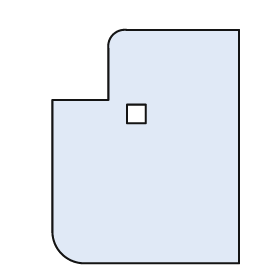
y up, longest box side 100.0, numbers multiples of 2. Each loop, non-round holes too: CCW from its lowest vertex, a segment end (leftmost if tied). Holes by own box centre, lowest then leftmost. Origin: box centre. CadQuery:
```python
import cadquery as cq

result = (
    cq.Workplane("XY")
    .moveTo(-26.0, -50.0)
    .lineTo(40.0, -50.0)
    .lineTo(40.0, 50.0)
    .lineTo(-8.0, 50.0)
    .threePointArc((-14.0, 48.0), (-16.0, 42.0))
    .lineTo(-16.0, 20.0)
    .lineTo(-40.0, 20.0)
    .lineTo(-40.0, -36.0)
    .threePointArc((-36.0, -46.0), (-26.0, -50.0))
    .close()
    .moveTo(-8.0, 10.0)
    .lineTo(0.0, 10.0)
    .lineTo(0.0, 18.0)
    .lineTo(-8.0, 18.0)
    .close()
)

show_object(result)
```